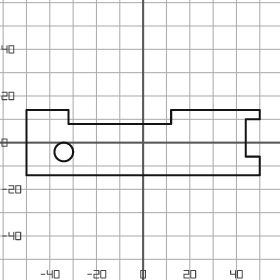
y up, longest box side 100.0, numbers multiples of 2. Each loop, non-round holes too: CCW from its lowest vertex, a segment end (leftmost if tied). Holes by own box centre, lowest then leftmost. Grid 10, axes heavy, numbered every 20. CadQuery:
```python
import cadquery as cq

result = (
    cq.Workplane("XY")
    .moveTo(-50.0, -14.0)
    .lineTo(50.0, -14.0)
    .lineTo(50.0, -6.0)
    .lineTo(44.0, -6.0)
    .lineTo(44.0, 10.0)
    .lineTo(50.0, 10.0)
    .lineTo(50.0, 14.0)
    .lineTo(12.0, 14.0)
    .lineTo(12.0, 8.0)
    .lineTo(-32.0, 8.0)
    .lineTo(-32.0, 14.0)
    .lineTo(-50.0, 14.0)
    .close()
    .moveTo(-34.0, -4.0)
    .circle(4.0)
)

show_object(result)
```